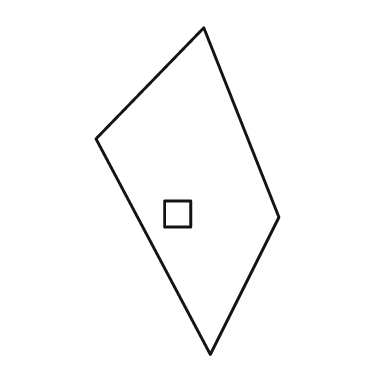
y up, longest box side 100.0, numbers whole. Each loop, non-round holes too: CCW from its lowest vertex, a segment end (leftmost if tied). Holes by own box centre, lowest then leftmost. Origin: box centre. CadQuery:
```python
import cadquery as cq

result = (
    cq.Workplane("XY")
    .moveTo(7.0, -50.0)
    .lineTo(28.0, -8.0)
    .lineTo(5.0, 50.0)
    .lineTo(-28.0, 16.0)
    .close()
    .moveTo(-7.0, -11.0)
    .lineTo(1.0, -11.0)
    .lineTo(1.0, -3.0)
    .lineTo(-7.0, -3.0)
    .close()
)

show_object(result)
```